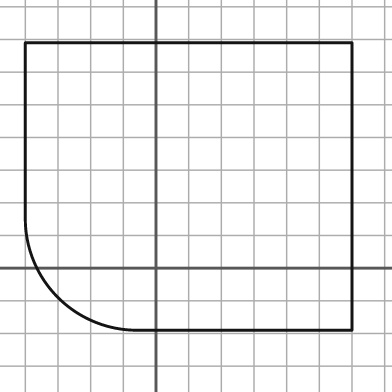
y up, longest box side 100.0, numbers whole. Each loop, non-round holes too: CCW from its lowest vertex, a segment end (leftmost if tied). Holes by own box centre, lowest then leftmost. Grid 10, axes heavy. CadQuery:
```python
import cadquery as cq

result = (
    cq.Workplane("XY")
    .moveTo(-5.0, -19.0)
    .lineTo(60.0, -19.0)
    .lineTo(60.0, 69.0)
    .lineTo(-40.0, 69.0)
    .lineTo(-40.0, 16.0)
    .threePointArc((-30.0, -9.0), (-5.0, -19.0))
    .close()
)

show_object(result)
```